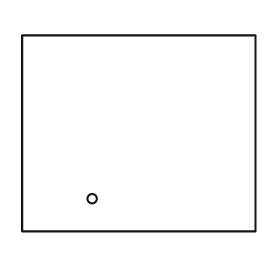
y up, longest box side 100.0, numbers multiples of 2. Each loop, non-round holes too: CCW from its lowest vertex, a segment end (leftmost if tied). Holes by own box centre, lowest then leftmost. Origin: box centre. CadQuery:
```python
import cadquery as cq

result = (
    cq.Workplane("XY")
    .moveTo(-50.0, -42.0)
    .lineTo(50.0, -42.0)
    .lineTo(50.0, 42.0)
    .lineTo(-50.0, 42.0)
    .close()
    .moveTo(-20.0, -28.0)
    .circle(2.0)
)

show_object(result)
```